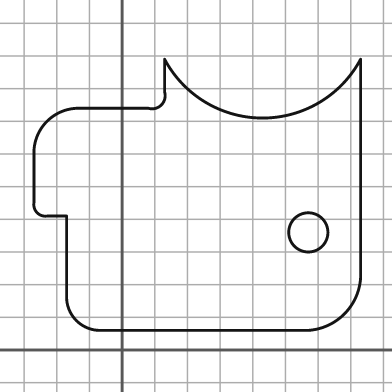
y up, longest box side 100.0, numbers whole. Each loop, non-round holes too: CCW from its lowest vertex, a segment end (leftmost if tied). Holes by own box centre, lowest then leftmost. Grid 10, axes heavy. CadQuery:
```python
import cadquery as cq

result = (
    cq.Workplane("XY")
    .moveTo(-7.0, 6.0)
    .lineTo(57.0, 6.0)
    .threePointArc((68.0, 11.0), (73.0, 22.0))
    .lineTo(73.0, 89.0)
    .threePointArc((43.0, 71.0), (13.0, 89.0))
    .lineTo(13.0, 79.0)
    .threePointArc((12.0, 75.0), (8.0, 74.0))
    .lineTo(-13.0, 74.0)
    .threePointArc((-23.0, 70.0), (-27.0, 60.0))
    .lineTo(-27.0, 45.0)
    .threePointArc((-26.0, 42.0), (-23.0, 41.0))
    .lineTo(-17.0, 41.0)
    .lineTo(-17.0, 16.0)
    .threePointArc((-14.0, 9.0), (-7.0, 6.0))
    .close()
    .moveTo(57.0, 36.0)
    .circle(6.0)
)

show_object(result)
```